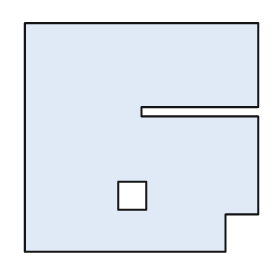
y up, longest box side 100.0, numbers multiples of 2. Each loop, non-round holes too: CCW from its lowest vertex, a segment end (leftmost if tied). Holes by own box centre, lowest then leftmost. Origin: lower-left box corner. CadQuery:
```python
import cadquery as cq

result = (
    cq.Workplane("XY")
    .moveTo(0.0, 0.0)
    .lineTo(86.0, 0.0)
    .lineTo(86.0, 16.0)
    .lineTo(100.0, 16.0)
    .lineTo(100.0, 58.0)
    .lineTo(50.0, 58.0)
    .lineTo(50.0, 62.0)
    .lineTo(100.0, 62.0)
    .lineTo(100.0, 98.0)
    .lineTo(0.0, 98.0)
    .close()
    .moveTo(40.0, 18.0)
    .lineTo(52.0, 18.0)
    .lineTo(52.0, 30.0)
    .lineTo(40.0, 30.0)
    .close()
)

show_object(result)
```